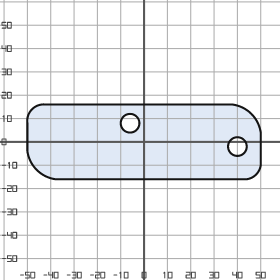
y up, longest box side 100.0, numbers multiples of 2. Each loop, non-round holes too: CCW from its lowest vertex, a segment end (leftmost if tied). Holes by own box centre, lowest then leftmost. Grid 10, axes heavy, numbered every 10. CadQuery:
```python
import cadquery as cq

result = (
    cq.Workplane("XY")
    .moveTo(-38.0, -16.0)
    .lineTo(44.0, -16.0)
    .threePointArc((48.0, -14.0), (50.0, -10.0))
    .lineTo(50.0, 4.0)
    .threePointArc((46.0, 12.0), (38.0, 16.0))
    .lineTo(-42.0, 16.0)
    .threePointArc((-48.0, 14.0), (-50.0, 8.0))
    .lineTo(-50.0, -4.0)
    .threePointArc((-46.0, -12.0), (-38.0, -16.0))
    .close()
    .moveTo(40.0, -2.0)
    .circle(4.0)
    .moveTo(-6.0, 8.0)
    .circle(4.0)
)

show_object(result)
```